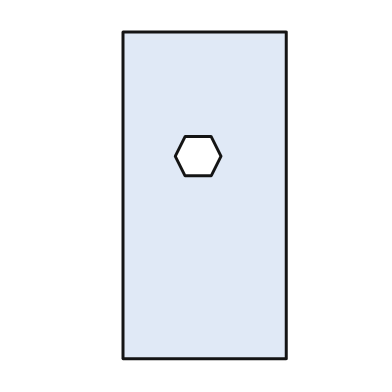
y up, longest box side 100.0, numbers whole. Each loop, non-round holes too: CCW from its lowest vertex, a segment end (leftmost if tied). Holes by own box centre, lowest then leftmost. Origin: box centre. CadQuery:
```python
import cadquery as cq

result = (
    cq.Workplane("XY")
    .moveTo(-25.0, -50.0)
    .lineTo(25.0, -50.0)
    .lineTo(25.0, 50.0)
    .lineTo(-25.0, 50.0)
    .close()
    .moveTo(-6.0, 6.0)
    .lineTo(2.0, 6.0)
    .lineTo(5.0, 12.0)
    .lineTo(2.0, 18.0)
    .lineTo(-6.0, 18.0)
    .lineTo(-9.0, 12.0)
    .close()
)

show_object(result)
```